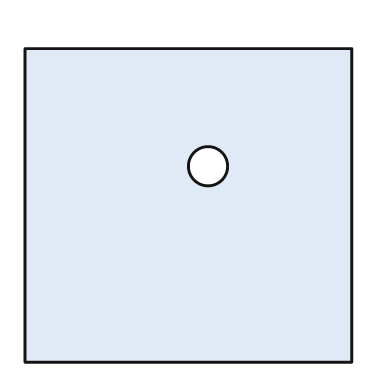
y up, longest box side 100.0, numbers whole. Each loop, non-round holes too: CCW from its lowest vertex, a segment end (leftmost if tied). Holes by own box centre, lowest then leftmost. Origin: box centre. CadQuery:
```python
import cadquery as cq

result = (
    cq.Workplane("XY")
    .moveTo(-50.0, -48.0)
    .lineTo(50.0, -48.0)
    .lineTo(50.0, 48.0)
    .lineTo(-50.0, 48.0)
    .close()
    .moveTo(6.0, 12.0)
    .circle(6.0)
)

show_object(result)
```